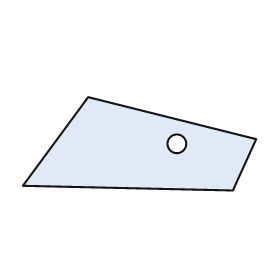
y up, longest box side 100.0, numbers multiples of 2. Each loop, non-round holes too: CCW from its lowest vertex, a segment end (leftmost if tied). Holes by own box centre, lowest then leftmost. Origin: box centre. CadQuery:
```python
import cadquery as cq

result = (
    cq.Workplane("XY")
    .moveTo(40.0, -20.0)
    .lineTo(50.0, 2.0)
    .lineTo(-22.0, 20.0)
    .lineTo(-50.0, -18.0)
    .close()
    .moveTo(16.0, 0.0)
    .circle(4.0)
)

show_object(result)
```